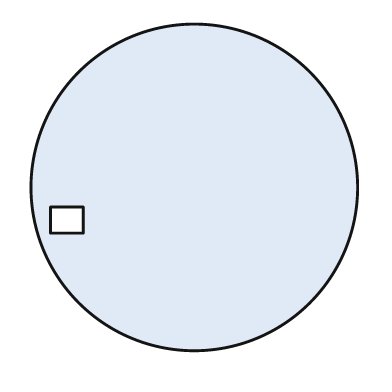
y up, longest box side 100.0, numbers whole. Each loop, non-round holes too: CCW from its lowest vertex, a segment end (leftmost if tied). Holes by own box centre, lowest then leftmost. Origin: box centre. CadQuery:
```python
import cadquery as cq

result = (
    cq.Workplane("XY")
    .moveTo(0.0, 0.0)
    .circle(50.0)
    .moveTo(-44.0, -14.0)
    .lineTo(-34.0, -14.0)
    .lineTo(-34.0, -6.0)
    .lineTo(-44.0, -6.0)
    .close()
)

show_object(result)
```